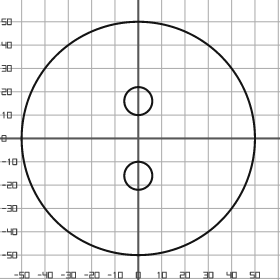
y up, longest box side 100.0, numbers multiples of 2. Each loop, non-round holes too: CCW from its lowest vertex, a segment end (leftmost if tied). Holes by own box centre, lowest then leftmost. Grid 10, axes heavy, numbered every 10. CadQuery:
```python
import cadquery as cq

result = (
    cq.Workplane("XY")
    .moveTo(0.0, 0.0)
    .circle(50.0)
    .moveTo(0.0, -16.0)
    .circle(6.0)
    .moveTo(0.0, 16.0)
    .circle(6.0)
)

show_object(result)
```